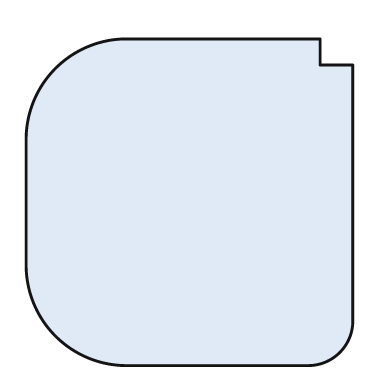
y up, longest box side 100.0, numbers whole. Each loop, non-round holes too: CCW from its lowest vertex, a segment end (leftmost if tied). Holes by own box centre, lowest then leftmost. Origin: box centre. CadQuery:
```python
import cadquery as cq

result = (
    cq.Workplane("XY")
    .moveTo(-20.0, -50.0)
    .lineTo(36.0, -50.0)
    .threePointArc((46.0, -46.0), (50.0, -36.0))
    .lineTo(50.0, 42.0)
    .lineTo(40.0, 42.0)
    .lineTo(40.0, 50.0)
    .lineTo(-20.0, 50.0)
    .threePointArc((-41.0, 41.0), (-50.0, 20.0))
    .lineTo(-50.0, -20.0)
    .threePointArc((-41.0, -41.0), (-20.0, -50.0))
    .close()
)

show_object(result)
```